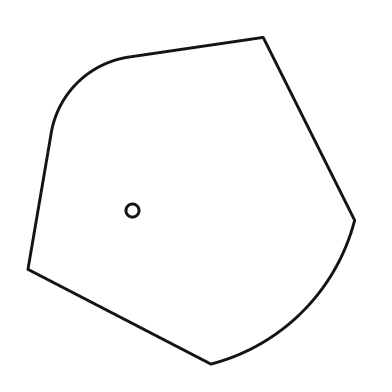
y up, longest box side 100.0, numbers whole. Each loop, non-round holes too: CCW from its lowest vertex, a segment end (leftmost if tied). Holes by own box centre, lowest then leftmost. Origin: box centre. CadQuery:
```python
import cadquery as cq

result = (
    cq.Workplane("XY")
    .moveTo(6.0, -50.0)
    .threePointArc((34.0, -34.0), (50.0, -6.0))
    .lineTo(22.0, 50.0)
    .lineTo(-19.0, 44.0)
    .threePointArc((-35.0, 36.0), (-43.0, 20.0))
    .lineTo(-50.0, -21.0)
    .close()
    .moveTo(-18.0, -3.0)
    .circle(2.0)
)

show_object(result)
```